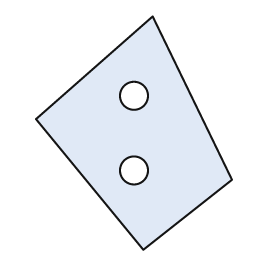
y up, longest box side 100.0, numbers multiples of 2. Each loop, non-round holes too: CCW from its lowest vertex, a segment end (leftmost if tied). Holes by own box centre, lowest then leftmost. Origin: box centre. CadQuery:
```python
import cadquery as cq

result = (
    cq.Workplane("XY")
    .moveTo(4.0, -50.0)
    .lineTo(42.0, -20.0)
    .lineTo(8.0, 50.0)
    .lineTo(-42.0, 6.0)
    .close()
    .moveTo(0.0, -16.0)
    .circle(6.0)
    .moveTo(0.0, 16.0)
    .circle(6.0)
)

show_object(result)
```